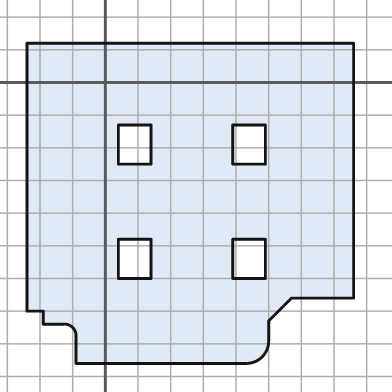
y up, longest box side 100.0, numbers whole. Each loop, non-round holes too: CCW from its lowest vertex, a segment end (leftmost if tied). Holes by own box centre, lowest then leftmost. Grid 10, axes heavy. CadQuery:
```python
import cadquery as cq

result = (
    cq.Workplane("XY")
    .moveTo(-9.0, -86.0)
    .lineTo(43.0, -86.0)
    .threePointArc((48.0, -84.0), (50.0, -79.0))
    .lineTo(50.0, -73.0)
    .lineTo(57.0, -66.0)
    .lineTo(76.0, -66.0)
    .lineTo(76.0, 12.0)
    .lineTo(-24.0, 12.0)
    .lineTo(-24.0, -70.0)
    .lineTo(-19.0, -70.0)
    .lineTo(-19.0, -74.0)
    .lineTo(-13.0, -74.0)
    .threePointArc((-10.0, -75.0), (-9.0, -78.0))
    .close()
    .moveTo(4.0, -60.0)
    .lineTo(14.0, -60.0)
    .lineTo(14.0, -48.0)
    .lineTo(4.0, -48.0)
    .close()
    .moveTo(39.0, -60.0)
    .lineTo(49.0, -60.0)
    .lineTo(49.0, -48.0)
    .lineTo(39.0, -48.0)
    .close()
    .moveTo(4.0, -25.0)
    .lineTo(14.0, -25.0)
    .lineTo(14.0, -13.0)
    .lineTo(4.0, -13.0)
    .close()
    .moveTo(39.0, -25.0)
    .lineTo(49.0, -25.0)
    .lineTo(49.0, -13.0)
    .lineTo(39.0, -13.0)
    .close()
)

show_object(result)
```